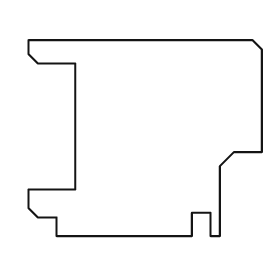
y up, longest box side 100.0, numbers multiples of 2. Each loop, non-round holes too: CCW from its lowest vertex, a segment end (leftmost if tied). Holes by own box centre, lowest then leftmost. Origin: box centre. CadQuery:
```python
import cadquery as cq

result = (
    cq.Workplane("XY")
    .moveTo(-38.0, -42.0)
    .lineTo(20.0, -42.0)
    .lineTo(20.0, -32.0)
    .lineTo(28.0, -32.0)
    .lineTo(28.0, -42.0)
    .lineTo(32.0, -42.0)
    .lineTo(32.0, -12.0)
    .lineTo(38.0, -6.0)
    .lineTo(50.0, -6.0)
    .lineTo(50.0, 38.0)
    .lineTo(46.0, 42.0)
    .lineTo(-50.0, 42.0)
    .lineTo(-50.0, 36.0)
    .lineTo(-46.0, 32.0)
    .lineTo(-30.0, 32.0)
    .lineTo(-30.0, -22.0)
    .lineTo(-50.0, -22.0)
    .lineTo(-50.0, -30.0)
    .lineTo(-46.0, -34.0)
    .lineTo(-38.0, -34.0)
    .close()
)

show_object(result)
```